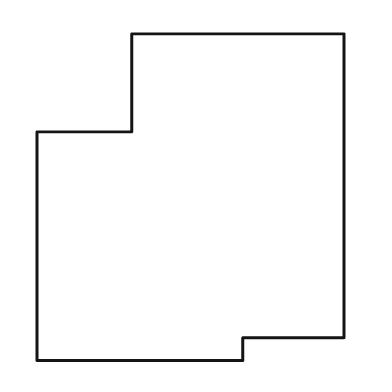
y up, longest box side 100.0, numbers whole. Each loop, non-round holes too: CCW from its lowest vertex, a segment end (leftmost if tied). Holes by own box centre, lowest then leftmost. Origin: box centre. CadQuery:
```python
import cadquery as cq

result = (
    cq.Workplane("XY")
    .moveTo(-47.0, -50.0)
    .lineTo(16.0, -50.0)
    .lineTo(16.0, -43.0)
    .lineTo(47.0, -43.0)
    .lineTo(47.0, 50.0)
    .lineTo(-18.0, 50.0)
    .lineTo(-18.0, 20.0)
    .lineTo(-47.0, 20.0)
    .close()
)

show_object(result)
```